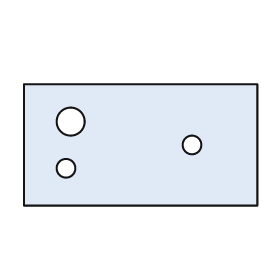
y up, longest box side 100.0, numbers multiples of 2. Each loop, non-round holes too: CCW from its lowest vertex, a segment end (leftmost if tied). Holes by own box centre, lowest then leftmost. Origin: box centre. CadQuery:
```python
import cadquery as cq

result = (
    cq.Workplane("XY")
    .moveTo(-50.0, -26.0)
    .lineTo(50.0, -26.0)
    .lineTo(50.0, 26.0)
    .lineTo(-50.0, 26.0)
    .close()
    .moveTo(-32.0, -10.0)
    .circle(4.0)
    .moveTo(22.0, 0.0)
    .circle(4.0)
    .moveTo(-30.0, 10.0)
    .circle(6.0)
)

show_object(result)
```